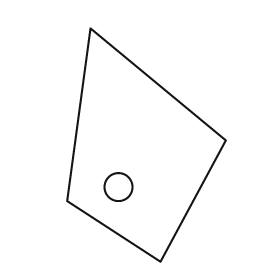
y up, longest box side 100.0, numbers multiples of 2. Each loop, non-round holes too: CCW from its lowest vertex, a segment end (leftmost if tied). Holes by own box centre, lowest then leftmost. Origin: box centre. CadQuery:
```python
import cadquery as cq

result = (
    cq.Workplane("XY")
    .moveTo(6.0, -50.0)
    .lineTo(34.0, 2.0)
    .lineTo(-24.0, 50.0)
    .lineTo(-34.0, -24.0)
    .close()
    .moveTo(-12.0, -18.0)
    .circle(6.0)
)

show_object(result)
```